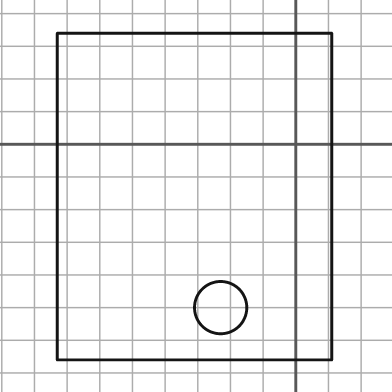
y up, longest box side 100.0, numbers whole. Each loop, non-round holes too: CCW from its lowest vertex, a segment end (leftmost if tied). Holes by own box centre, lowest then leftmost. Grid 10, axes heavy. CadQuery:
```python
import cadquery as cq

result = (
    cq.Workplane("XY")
    .moveTo(-73.0, -66.0)
    .lineTo(11.0, -66.0)
    .lineTo(11.0, 34.0)
    .lineTo(-73.0, 34.0)
    .close()
    .moveTo(-23.0, -50.0)
    .circle(8.0)
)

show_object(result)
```